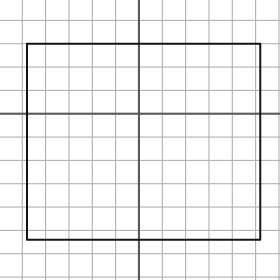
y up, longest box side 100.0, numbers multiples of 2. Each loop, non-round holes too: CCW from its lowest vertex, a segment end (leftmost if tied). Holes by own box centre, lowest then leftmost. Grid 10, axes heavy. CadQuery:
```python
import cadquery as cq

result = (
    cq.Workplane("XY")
    .moveTo(-48.0, -54.0)
    .lineTo(52.0, -54.0)
    .lineTo(52.0, 30.0)
    .lineTo(-48.0, 30.0)
    .close()
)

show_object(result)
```